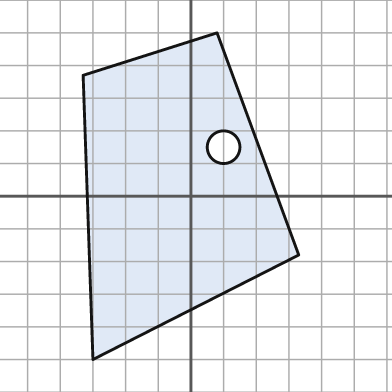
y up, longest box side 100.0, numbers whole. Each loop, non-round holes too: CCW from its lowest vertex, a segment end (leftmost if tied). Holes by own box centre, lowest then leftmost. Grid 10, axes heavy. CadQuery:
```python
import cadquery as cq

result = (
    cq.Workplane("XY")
    .moveTo(-30.0, -50.0)
    .lineTo(33.0, -18.0)
    .lineTo(8.0, 50.0)
    .lineTo(-33.0, 37.0)
    .close()
    .moveTo(10.0, 15.0)
    .circle(5.0)
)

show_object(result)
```